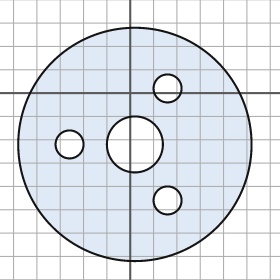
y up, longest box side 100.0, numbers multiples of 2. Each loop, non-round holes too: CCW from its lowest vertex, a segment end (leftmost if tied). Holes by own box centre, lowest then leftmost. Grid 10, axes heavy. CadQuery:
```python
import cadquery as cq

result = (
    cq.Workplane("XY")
    .moveTo(2.0, -22.0)
    .circle(50.0)
    .moveTo(16.0, -46.0)
    .circle(6.0)
    .moveTo(-26.0, -22.0)
    .circle(6.0)
    .moveTo(2.0, -22.0)
    .circle(12.0)
    .moveTo(16.0, 2.0)
    .circle(6.0)
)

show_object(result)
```